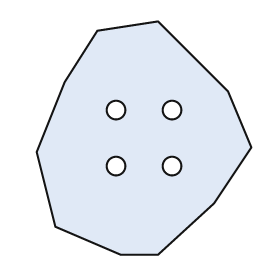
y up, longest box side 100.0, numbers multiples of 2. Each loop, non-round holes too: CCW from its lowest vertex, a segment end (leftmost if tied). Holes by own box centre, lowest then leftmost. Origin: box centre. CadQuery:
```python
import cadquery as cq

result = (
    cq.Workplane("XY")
    .moveTo(-10.0, -50.0)
    .lineTo(6.0, -50.0)
    .lineTo(30.0, -28.0)
    .lineTo(46.0, -4.0)
    .lineTo(36.0, 20.0)
    .lineTo(6.0, 50.0)
    .lineTo(-20.0, 46.0)
    .lineTo(-34.0, 24.0)
    .lineTo(-46.0, -6.0)
    .lineTo(-38.0, -38.0)
    .close()
    .moveTo(-12.0, -12.0)
    .circle(4.0)
    .moveTo(12.0, -12.0)
    .circle(4.0)
    .moveTo(-12.0, 12.0)
    .circle(4.0)
    .moveTo(12.0, 12.0)
    .circle(4.0)
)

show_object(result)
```